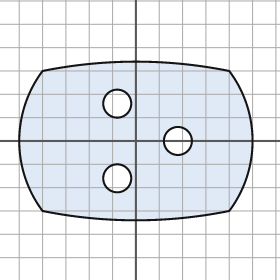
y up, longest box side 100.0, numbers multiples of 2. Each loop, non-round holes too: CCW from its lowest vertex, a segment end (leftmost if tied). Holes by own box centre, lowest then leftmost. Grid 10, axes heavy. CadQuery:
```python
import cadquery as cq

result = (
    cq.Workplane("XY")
    .moveTo(-40.0, -30.0)
    .threePointArc((0.0, -34.0), (40.0, -30.0))
    .threePointArc((50.0, 0.0), (40.0, 30.0))
    .threePointArc((0.0, 34.0), (-40.0, 30.0))
    .threePointArc((-50.0, 0.0), (-40.0, -30.0))
    .close()
    .moveTo(-8.0, -16.0)
    .circle(6.0)
    .moveTo(18.0, 0.0)
    .circle(6.0)
    .moveTo(-8.0, 16.0)
    .circle(6.0)
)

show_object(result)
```